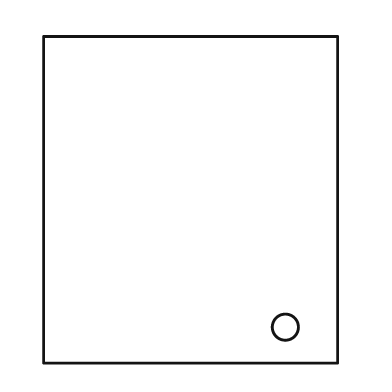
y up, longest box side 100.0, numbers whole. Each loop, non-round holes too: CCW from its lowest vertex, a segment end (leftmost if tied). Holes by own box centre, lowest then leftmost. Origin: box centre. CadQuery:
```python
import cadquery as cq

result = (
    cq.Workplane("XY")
    .moveTo(-45.0, -50.0)
    .lineTo(45.0, -50.0)
    .lineTo(45.0, 50.0)
    .lineTo(-45.0, 50.0)
    .close()
    .moveTo(29.0, -39.0)
    .circle(4.0)
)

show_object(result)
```